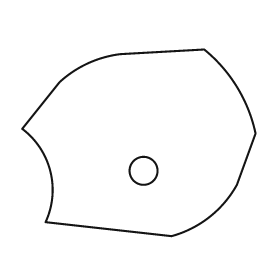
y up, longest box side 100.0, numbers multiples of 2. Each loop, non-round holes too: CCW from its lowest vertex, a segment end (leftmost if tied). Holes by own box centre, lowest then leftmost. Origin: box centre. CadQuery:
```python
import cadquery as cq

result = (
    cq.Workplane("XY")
    .moveTo(14.0, -40.0)
    .threePointArc((30.0, -32.0), (42.0, -18.0))
    .lineTo(50.0, 4.0)
    .threePointArc((42.0, 24.0), (28.0, 40.0))
    .lineTo(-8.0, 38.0)
    .threePointArc((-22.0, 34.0), (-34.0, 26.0))
    .lineTo(-50.0, 6.0)
    .threePointArc((-38.0, -12.0), (-40.0, -34.0))
    .close()
    .moveTo(2.0, -12.0)
    .circle(6.0)
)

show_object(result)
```